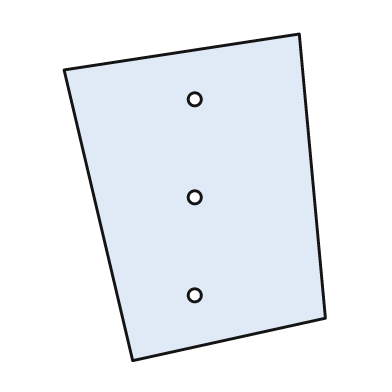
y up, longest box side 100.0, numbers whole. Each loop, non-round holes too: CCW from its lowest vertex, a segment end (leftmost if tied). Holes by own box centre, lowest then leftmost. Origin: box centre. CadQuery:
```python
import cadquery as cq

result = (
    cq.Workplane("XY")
    .moveTo(-19.0, -50.0)
    .lineTo(40.0, -37.0)
    .lineTo(32.0, 50.0)
    .lineTo(-40.0, 39.0)
    .close()
    .moveTo(0.0, -30.0)
    .circle(2.0)
    .moveTo(0.0, 0.0)
    .circle(2.0)
    .moveTo(0.0, 30.0)
    .circle(2.0)
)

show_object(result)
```